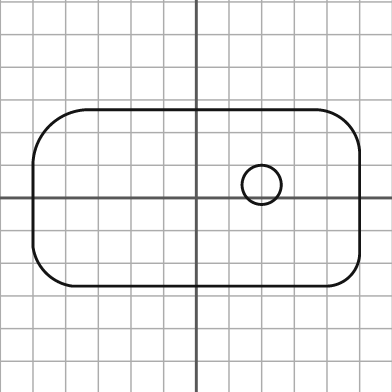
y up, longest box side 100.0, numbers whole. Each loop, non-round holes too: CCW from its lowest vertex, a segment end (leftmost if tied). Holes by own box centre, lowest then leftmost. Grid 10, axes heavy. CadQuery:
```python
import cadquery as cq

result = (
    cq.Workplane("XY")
    .moveTo(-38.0, -27.0)
    .lineTo(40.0, -27.0)
    .threePointArc((47.0, -24.0), (50.0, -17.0))
    .lineTo(50.0, 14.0)
    .threePointArc((46.0, 23.0), (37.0, 27.0))
    .lineTo(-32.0, 27.0)
    .threePointArc((-45.0, 22.0), (-50.0, 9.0))
    .lineTo(-50.0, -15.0)
    .threePointArc((-46.0, -23.0), (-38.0, -27.0))
    .close()
    .moveTo(20.0, 4.0)
    .circle(6.0)
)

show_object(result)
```